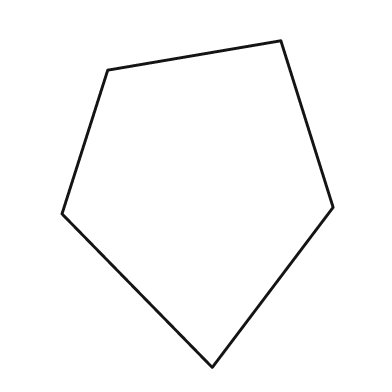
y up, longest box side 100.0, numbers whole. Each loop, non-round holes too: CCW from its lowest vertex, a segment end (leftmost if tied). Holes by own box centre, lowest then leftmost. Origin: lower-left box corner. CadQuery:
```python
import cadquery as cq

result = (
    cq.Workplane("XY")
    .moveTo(46.0, 0.0)
    .lineTo(83.0, 49.0)
    .lineTo(67.0, 100.0)
    .lineTo(14.0, 91.0)
    .lineTo(0.0, 47.0)
    .close()
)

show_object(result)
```